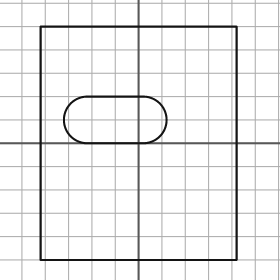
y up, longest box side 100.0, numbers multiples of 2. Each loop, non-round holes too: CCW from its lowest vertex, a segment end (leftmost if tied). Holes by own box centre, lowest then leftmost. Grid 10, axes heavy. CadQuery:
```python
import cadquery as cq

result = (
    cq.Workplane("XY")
    .moveTo(-42.0, -50.0)
    .lineTo(42.0, -50.0)
    .lineTo(42.0, 50.0)
    .lineTo(-42.0, 50.0)
    .close()
    .moveTo(-22.0, 0.0)
    .lineTo(2.0, 0.0)
    .threePointArc((12.0, 10.0), (2.0, 20.0))
    .lineTo(-22.0, 20.0)
    .threePointArc((-32.0, 10.0), (-22.0, 0.0))
    .close()
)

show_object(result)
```